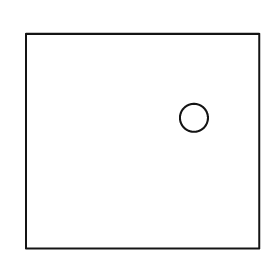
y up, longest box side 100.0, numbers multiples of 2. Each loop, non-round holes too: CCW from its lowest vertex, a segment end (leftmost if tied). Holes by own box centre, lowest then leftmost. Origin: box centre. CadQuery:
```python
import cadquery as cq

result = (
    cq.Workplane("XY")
    .moveTo(-50.0, -46.0)
    .lineTo(50.0, -46.0)
    .lineTo(50.0, 46.0)
    .lineTo(-50.0, 46.0)
    .close()
    .moveTo(22.0, 10.0)
    .circle(6.0)
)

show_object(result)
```